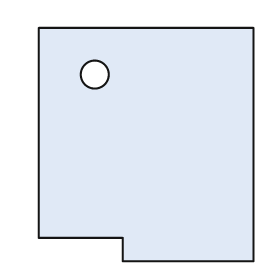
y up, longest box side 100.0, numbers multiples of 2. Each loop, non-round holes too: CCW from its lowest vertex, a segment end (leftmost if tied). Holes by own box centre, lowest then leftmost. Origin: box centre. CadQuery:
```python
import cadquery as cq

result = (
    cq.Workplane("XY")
    .moveTo(-10.0, -50.0)
    .lineTo(46.0, -50.0)
    .lineTo(46.0, 50.0)
    .lineTo(-46.0, 50.0)
    .lineTo(-46.0, -40.0)
    .lineTo(-10.0, -40.0)
    .close()
    .moveTo(-22.0, 30.0)
    .circle(6.0)
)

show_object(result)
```